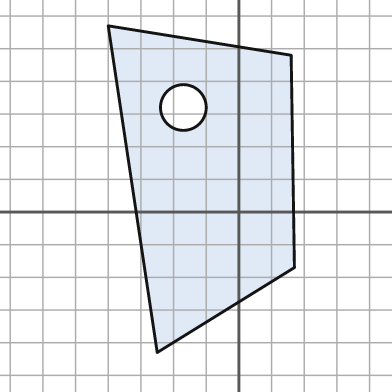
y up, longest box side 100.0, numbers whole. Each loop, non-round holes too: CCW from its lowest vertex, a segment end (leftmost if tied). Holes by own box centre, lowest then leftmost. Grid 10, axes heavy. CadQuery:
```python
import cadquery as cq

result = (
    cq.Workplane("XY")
    .moveTo(-25.0, -43.0)
    .lineTo(17.0, -17.0)
    .lineTo(16.0, 48.0)
    .lineTo(-40.0, 57.0)
    .close()
    .moveTo(-17.0, 32.0)
    .circle(7.0)
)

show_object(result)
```